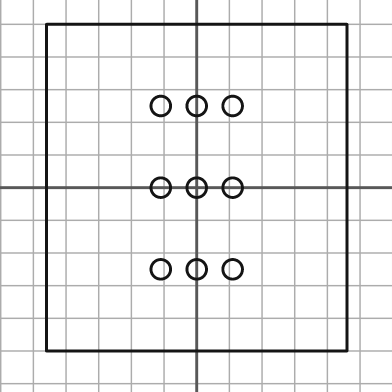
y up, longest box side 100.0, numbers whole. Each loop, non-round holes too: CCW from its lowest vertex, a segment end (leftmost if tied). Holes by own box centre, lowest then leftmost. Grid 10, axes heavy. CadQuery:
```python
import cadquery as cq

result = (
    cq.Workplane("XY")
    .moveTo(-46.0, -50.0)
    .lineTo(46.0, -50.0)
    .lineTo(46.0, 50.0)
    .lineTo(-46.0, 50.0)
    .close()
    .moveTo(-11.0, -25.0)
    .circle(3.0)
    .moveTo(0.0, -25.0)
    .circle(3.0)
    .moveTo(11.0, -25.0)
    .circle(3.0)
    .moveTo(-11.0, 0.0)
    .circle(3.0)
    .moveTo(0.0, 0.0)
    .circle(3.0)
    .moveTo(11.0, 0.0)
    .circle(3.0)
    .moveTo(-11.0, 25.0)
    .circle(3.0)
    .moveTo(0.0, 25.0)
    .circle(3.0)
    .moveTo(11.0, 25.0)
    .circle(3.0)
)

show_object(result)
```